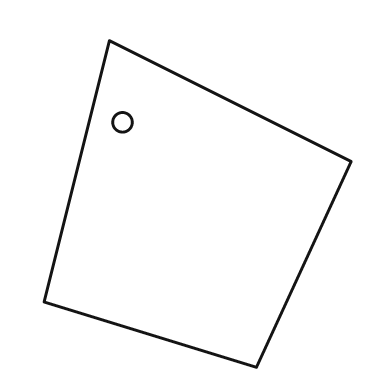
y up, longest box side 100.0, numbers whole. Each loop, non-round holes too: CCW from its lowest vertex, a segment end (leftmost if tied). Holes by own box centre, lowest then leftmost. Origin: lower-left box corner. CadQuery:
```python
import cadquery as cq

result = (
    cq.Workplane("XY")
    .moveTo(65.0, 0.0)
    .lineTo(94.0, 63.0)
    .lineTo(20.0, 100.0)
    .lineTo(0.0, 20.0)
    .close()
    .moveTo(24.0, 75.0)
    .circle(3.0)
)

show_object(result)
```